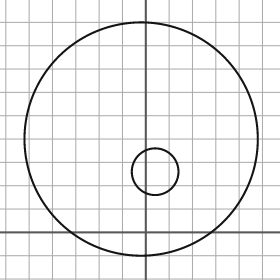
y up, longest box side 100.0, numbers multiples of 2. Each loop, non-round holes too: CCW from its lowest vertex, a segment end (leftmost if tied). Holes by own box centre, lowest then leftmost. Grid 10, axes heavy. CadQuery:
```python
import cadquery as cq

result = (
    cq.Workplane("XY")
    .moveTo(-2.0, 40.0)
    .circle(50.0)
    .moveTo(4.0, 26.0)
    .circle(10.0)
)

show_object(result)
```